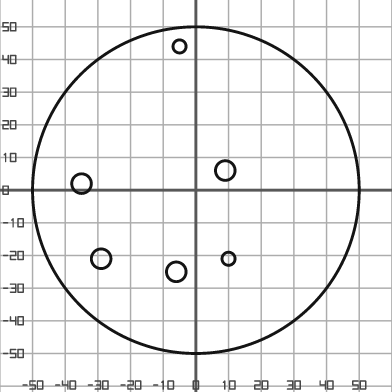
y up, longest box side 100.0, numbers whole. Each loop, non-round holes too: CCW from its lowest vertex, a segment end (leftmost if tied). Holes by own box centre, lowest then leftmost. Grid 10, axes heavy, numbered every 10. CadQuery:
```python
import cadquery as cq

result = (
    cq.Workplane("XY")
    .moveTo(0.0, 0.0)
    .circle(50.0)
    .moveTo(-6.0, -25.0)
    .circle(3.0)
    .moveTo(-29.0, -21.0)
    .circle(3.0)
    .moveTo(10.0, -21.0)
    .circle(2.0)
    .moveTo(-35.0, 2.0)
    .circle(3.0)
    .moveTo(9.0, 6.0)
    .circle(3.0)
    .moveTo(-5.0, 44.0)
    .circle(2.0)
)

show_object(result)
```